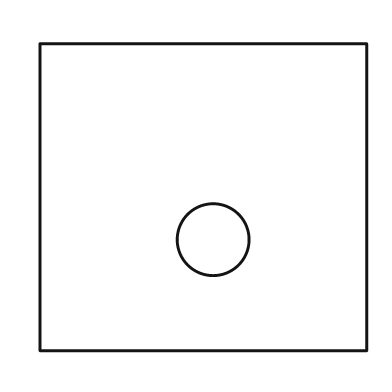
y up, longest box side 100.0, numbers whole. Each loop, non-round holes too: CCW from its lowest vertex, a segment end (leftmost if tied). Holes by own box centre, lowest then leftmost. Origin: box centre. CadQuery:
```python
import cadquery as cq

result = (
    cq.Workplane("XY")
    .moveTo(-50.0, -47.0)
    .lineTo(50.0, -47.0)
    .lineTo(50.0, 47.0)
    .lineTo(-50.0, 47.0)
    .close()
    .moveTo(3.0, -13.0)
    .circle(11.0)
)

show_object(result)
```